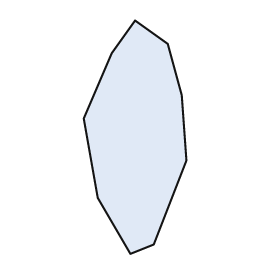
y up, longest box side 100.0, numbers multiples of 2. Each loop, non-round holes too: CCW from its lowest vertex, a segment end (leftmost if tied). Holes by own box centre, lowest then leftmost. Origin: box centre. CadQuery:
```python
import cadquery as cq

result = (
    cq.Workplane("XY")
    .moveTo(-2.0, -50.0)
    .lineTo(8.0, -46.0)
    .lineTo(22.0, -10.0)
    .lineTo(20.0, 18.0)
    .lineTo(14.0, 40.0)
    .lineTo(0.0, 50.0)
    .lineTo(-10.0, 36.0)
    .lineTo(-22.0, 8.0)
    .lineTo(-16.0, -26.0)
    .close()
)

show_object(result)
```